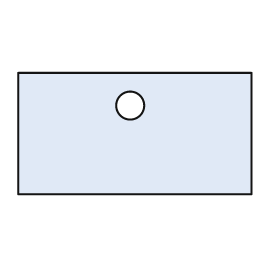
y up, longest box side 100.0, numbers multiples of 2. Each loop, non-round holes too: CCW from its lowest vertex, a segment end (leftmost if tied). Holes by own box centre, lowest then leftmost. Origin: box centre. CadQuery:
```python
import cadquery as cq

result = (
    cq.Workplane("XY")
    .moveTo(-50.0, -26.0)
    .lineTo(50.0, -26.0)
    .lineTo(50.0, 26.0)
    .lineTo(-50.0, 26.0)
    .close()
    .moveTo(-2.0, 12.0)
    .circle(6.0)
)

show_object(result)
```